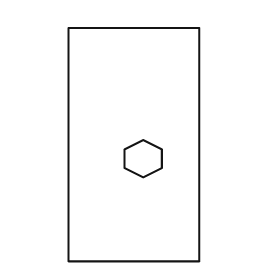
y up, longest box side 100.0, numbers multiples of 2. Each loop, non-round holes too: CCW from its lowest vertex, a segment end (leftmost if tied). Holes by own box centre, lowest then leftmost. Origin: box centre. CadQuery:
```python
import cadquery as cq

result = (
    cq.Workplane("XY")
    .moveTo(-28.0, -50.0)
    .lineTo(28.0, -50.0)
    .lineTo(28.0, 50.0)
    .lineTo(-28.0, 50.0)
    .close()
    .moveTo(4.0, -14.0)
    .lineTo(12.0, -10.0)
    .lineTo(12.0, -2.0)
    .lineTo(4.0, 2.0)
    .lineTo(-4.0, -2.0)
    .lineTo(-4.0, -10.0)
    .close()
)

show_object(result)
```